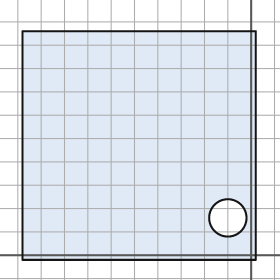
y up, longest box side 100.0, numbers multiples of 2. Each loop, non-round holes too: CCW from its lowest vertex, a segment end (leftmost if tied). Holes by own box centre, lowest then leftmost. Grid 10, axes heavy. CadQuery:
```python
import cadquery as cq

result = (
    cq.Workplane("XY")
    .moveTo(-98.0, -2.0)
    .lineTo(2.0, -2.0)
    .lineTo(2.0, 96.0)
    .lineTo(-98.0, 96.0)
    .close()
    .moveTo(-10.0, 16.0)
    .circle(8.0)
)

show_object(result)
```